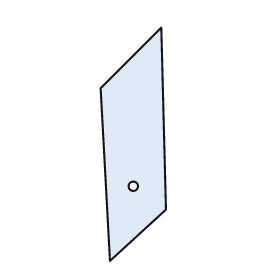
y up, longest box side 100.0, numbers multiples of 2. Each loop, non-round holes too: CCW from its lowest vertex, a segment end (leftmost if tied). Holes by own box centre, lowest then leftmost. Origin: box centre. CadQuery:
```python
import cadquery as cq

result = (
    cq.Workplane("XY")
    .moveTo(-10.0, -50.0)
    .lineTo(14.0, -28.0)
    .lineTo(12.0, 50.0)
    .lineTo(-14.0, 24.0)
    .close()
    .moveTo(0.0, -18.0)
    .circle(2.0)
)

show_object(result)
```